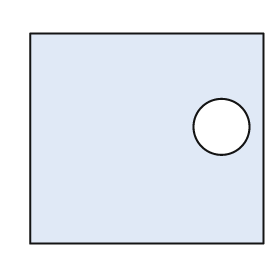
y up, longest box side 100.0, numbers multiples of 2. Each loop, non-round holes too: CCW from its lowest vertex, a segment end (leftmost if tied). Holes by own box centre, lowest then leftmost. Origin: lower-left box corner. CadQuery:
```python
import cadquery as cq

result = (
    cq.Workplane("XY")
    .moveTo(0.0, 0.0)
    .lineTo(100.0, 0.0)
    .lineTo(100.0, 90.0)
    .lineTo(0.0, 90.0)
    .close()
    .moveTo(82.0, 50.0)
    .circle(12.0)
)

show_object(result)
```